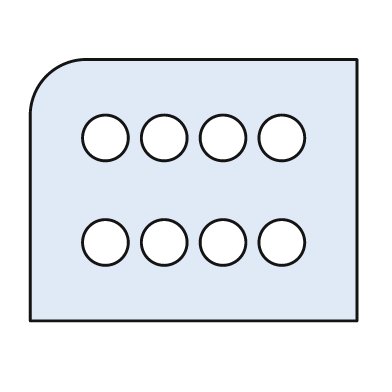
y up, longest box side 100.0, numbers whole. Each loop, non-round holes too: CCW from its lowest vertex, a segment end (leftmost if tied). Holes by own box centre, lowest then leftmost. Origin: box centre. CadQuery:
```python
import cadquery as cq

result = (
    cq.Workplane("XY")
    .moveTo(-50.0, -40.0)
    .lineTo(50.0, -40.0)
    .lineTo(50.0, 40.0)
    .lineTo(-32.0, 40.0)
    .threePointArc((-45.0, 35.0), (-50.0, 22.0))
    .close()
    .moveTo(-27.0, -16.0)
    .circle(7.0)
    .moveTo(-9.0, -16.0)
    .circle(7.0)
    .moveTo(9.0, -16.0)
    .circle(7.0)
    .moveTo(27.0, -16.0)
    .circle(7.0)
    .moveTo(-27.0, 16.0)
    .circle(7.0)
    .moveTo(-9.0, 16.0)
    .circle(7.0)
    .moveTo(9.0, 16.0)
    .circle(7.0)
    .moveTo(27.0, 16.0)
    .circle(7.0)
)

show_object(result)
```